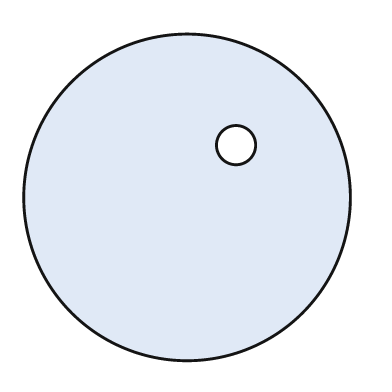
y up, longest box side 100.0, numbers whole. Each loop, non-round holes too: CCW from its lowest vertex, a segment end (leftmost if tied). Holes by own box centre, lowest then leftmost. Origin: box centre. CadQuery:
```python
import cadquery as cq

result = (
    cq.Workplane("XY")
    .moveTo(0.0, 0.0)
    .circle(50.0)
    .moveTo(15.0, 16.0)
    .circle(6.0)
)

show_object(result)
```